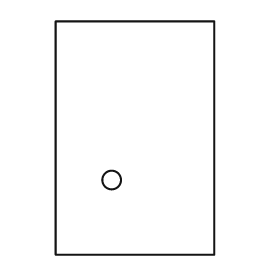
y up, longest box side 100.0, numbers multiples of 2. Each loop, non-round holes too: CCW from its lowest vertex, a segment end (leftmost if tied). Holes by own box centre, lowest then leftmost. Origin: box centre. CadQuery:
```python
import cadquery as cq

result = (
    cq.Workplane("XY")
    .moveTo(-34.0, -50.0)
    .lineTo(34.0, -50.0)
    .lineTo(34.0, 50.0)
    .lineTo(-34.0, 50.0)
    .close()
    .moveTo(-10.0, -18.0)
    .circle(4.0)
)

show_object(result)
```